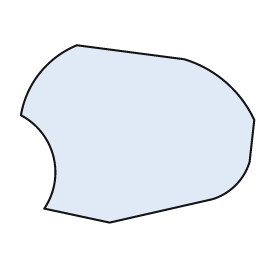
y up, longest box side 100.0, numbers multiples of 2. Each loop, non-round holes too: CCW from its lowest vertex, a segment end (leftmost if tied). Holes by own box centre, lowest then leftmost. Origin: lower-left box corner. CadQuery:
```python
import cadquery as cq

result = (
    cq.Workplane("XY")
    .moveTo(38.0, 0.0)
    .lineTo(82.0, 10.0)
    .threePointArc((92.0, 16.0), (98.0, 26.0))
    .lineTo(100.0, 44.0)
    .threePointArc((88.0, 60.0), (70.0, 70.0))
    .lineTo(24.0, 76.0)
    .threePointArc((8.0, 64.0), (0.0, 46.0))
    .threePointArc((14.0, 28.0), (10.0, 6.0))
    .close()
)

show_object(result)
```